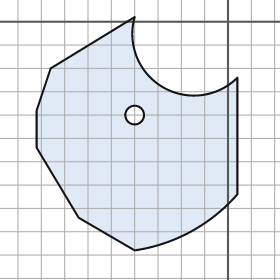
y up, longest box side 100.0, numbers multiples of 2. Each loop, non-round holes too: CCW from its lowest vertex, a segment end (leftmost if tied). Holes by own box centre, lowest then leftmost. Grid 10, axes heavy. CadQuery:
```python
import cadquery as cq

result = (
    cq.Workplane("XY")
    .moveTo(-40.0, -98.0)
    .threePointArc((-16.0, -90.0), (4.0, -74.0))
    .lineTo(4.0, -24.0)
    .threePointArc((-28.0, -28.0), (-40.0, 2.0))
    .lineTo(-76.0, -20.0)
    .lineTo(-82.0, -38.0)
    .lineTo(-82.0, -54.0)
    .lineTo(-64.0, -84.0)
    .close()
    .moveTo(-40.0, -40.0)
    .circle(4.0)
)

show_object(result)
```